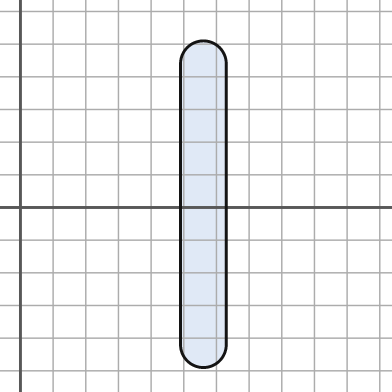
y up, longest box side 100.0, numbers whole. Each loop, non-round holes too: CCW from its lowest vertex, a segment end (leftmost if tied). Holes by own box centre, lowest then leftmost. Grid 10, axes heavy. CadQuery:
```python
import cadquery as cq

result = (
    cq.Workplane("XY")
    .moveTo(49.0, -42.0)
    .threePointArc((56.0, -49.0), (63.0, -42.0))
    .lineTo(63.0, 44.0)
    .threePointArc((56.0, 51.0), (49.0, 44.0))
    .close()
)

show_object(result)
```